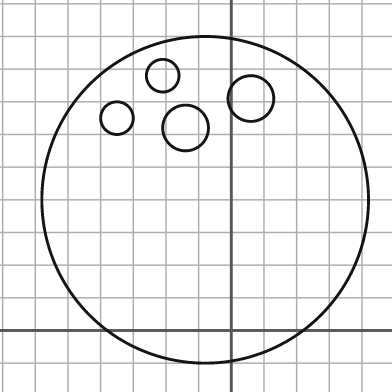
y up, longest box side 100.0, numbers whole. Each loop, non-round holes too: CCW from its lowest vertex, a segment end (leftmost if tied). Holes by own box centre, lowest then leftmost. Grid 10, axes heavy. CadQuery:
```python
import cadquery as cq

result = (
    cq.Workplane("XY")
    .moveTo(-8.0, 40.0)
    .circle(50.0)
    .moveTo(-14.0, 62.0)
    .circle(7.0)
    .moveTo(-35.0, 65.0)
    .circle(5.0)
    .moveTo(6.0, 71.0)
    .circle(7.0)
    .moveTo(-21.0, 78.0)
    .circle(5.0)
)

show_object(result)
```